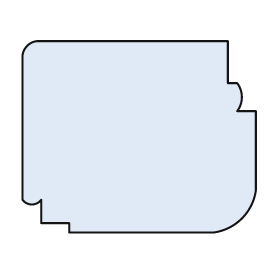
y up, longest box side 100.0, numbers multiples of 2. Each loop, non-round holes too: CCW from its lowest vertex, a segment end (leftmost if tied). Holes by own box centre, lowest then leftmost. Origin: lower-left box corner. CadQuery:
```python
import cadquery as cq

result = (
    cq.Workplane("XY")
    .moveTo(20.0, 0.0)
    .lineTo(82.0, 0.0)
    .threePointArc((94.0, 6.0), (100.0, 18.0))
    .lineTo(100.0, 52.0)
    .lineTo(92.0, 52.0)
    .threePointArc((94.0, 58.0), (92.0, 64.0))
    .lineTo(88.0, 64.0)
    .lineTo(88.0, 82.0)
    .lineTo(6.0, 82.0)
    .threePointArc((2.0, 80.0), (0.0, 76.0))
    .lineTo(0.0, 14.0)
    .threePointArc((4.0, 12.0), (8.0, 14.0))
    .lineTo(8.0, 4.0)
    .lineTo(20.0, 4.0)
    .close()
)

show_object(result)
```